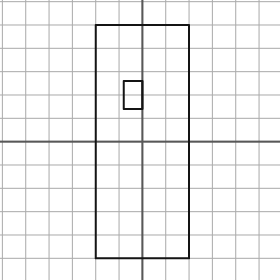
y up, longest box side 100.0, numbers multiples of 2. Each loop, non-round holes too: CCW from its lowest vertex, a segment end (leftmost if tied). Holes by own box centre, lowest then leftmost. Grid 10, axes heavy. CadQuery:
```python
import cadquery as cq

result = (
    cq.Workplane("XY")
    .moveTo(-20.0, -50.0)
    .lineTo(20.0, -50.0)
    .lineTo(20.0, 50.0)
    .lineTo(-20.0, 50.0)
    .close()
    .moveTo(-8.0, 14.0)
    .lineTo(0.0, 14.0)
    .lineTo(0.0, 26.0)
    .lineTo(-8.0, 26.0)
    .close()
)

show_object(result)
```